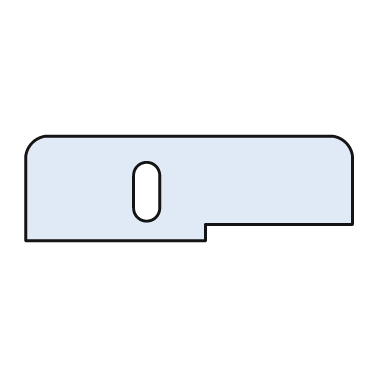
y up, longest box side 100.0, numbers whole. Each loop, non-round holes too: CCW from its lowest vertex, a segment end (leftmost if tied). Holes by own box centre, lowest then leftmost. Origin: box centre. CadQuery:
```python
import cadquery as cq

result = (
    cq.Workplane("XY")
    .moveTo(-50.0, -16.0)
    .lineTo(5.0, -16.0)
    .lineTo(5.0, -11.0)
    .lineTo(50.0, -11.0)
    .lineTo(50.0, 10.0)
    .threePointArc((48.0, 14.0), (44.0, 16.0))
    .lineTo(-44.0, 16.0)
    .threePointArc((-48.0, 14.0), (-50.0, 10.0))
    .close()
    .moveTo(-17.0, -6.0)
    .threePointArc((-13.0, -10.0), (-9.0, -6.0))
    .lineTo(-9.0, 4.0)
    .threePointArc((-13.0, 8.0), (-17.0, 4.0))
    .close()
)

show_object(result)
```